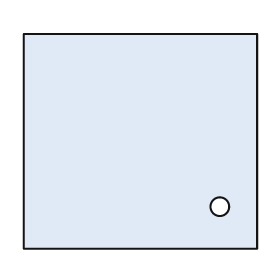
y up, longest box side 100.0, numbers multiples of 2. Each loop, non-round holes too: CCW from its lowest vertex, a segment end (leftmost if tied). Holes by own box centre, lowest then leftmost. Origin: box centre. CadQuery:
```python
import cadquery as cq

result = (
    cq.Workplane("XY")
    .moveTo(-50.0, -46.0)
    .lineTo(50.0, -46.0)
    .lineTo(50.0, 46.0)
    .lineTo(-50.0, 46.0)
    .close()
    .moveTo(34.0, -28.0)
    .circle(4.0)
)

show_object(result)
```